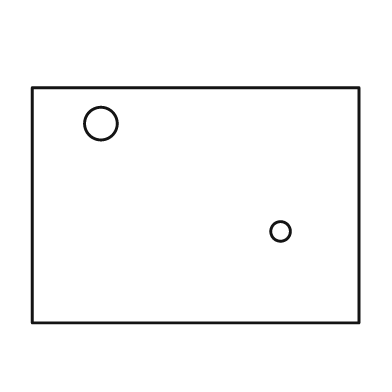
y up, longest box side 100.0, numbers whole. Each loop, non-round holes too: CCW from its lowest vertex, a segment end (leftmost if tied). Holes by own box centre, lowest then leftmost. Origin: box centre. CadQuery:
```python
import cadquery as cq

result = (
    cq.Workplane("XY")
    .moveTo(-50.0, -36.0)
    .lineTo(50.0, -36.0)
    .lineTo(50.0, 36.0)
    .lineTo(-50.0, 36.0)
    .close()
    .moveTo(26.0, -8.0)
    .circle(3.0)
    .moveTo(-29.0, 25.0)
    .circle(5.0)
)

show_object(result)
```